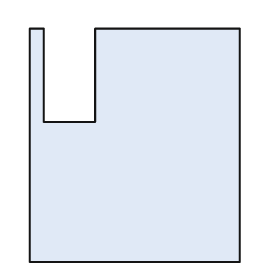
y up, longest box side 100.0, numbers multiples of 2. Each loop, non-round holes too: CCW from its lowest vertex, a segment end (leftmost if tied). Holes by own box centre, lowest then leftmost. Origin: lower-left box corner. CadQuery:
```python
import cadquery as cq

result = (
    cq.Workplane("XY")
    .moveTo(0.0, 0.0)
    .lineTo(90.0, 0.0)
    .lineTo(90.0, 100.0)
    .lineTo(28.0, 100.0)
    .lineTo(28.0, 60.0)
    .lineTo(6.0, 60.0)
    .lineTo(6.0, 100.0)
    .lineTo(0.0, 100.0)
    .close()
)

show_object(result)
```